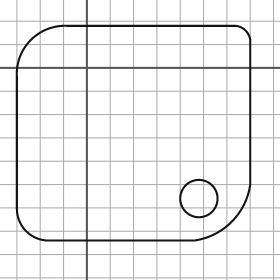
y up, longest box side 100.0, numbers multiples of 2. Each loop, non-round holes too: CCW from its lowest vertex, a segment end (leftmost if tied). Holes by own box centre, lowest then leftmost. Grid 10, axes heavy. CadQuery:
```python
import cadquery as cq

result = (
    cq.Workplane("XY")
    .moveTo(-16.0, -74.0)
    .lineTo(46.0, -74.0)
    .threePointArc((62.0, -66.0), (70.0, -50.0))
    .lineTo(70.0, 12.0)
    .threePointArc((68.0, 16.0), (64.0, 18.0))
    .lineTo(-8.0, 18.0)
    .threePointArc((-24.0, 12.0), (-30.0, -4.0))
    .lineTo(-30.0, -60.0)
    .threePointArc((-26.0, -70.0), (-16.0, -74.0))
    .close()
    .moveTo(48.0, -56.0)
    .circle(8.0)
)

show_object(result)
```